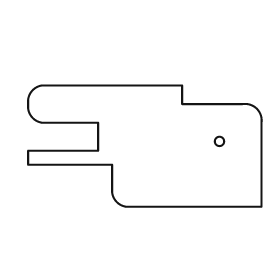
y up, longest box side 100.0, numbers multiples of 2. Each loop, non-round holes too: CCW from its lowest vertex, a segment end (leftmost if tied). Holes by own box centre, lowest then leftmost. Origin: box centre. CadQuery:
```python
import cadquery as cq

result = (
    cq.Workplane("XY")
    .moveTo(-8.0, -26.0)
    .lineTo(50.0, -26.0)
    .lineTo(50.0, 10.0)
    .threePointArc((48.0, 16.0), (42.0, 18.0))
    .lineTo(16.0, 18.0)
    .lineTo(16.0, 26.0)
    .lineTo(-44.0, 26.0)
    .threePointArc((-48.0, 24.0), (-50.0, 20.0))
    .lineTo(-50.0, 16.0)
    .threePointArc((-48.0, 12.0), (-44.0, 10.0))
    .lineTo(-20.0, 10.0)
    .lineTo(-20.0, -2.0)
    .lineTo(-50.0, -2.0)
    .lineTo(-50.0, -8.0)
    .lineTo(-14.0, -8.0)
    .lineTo(-14.0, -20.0)
    .threePointArc((-12.0, -24.0), (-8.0, -26.0))
    .close()
    .moveTo(32.0, 2.0)
    .circle(2.0)
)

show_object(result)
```